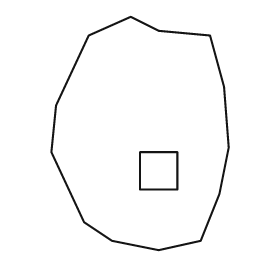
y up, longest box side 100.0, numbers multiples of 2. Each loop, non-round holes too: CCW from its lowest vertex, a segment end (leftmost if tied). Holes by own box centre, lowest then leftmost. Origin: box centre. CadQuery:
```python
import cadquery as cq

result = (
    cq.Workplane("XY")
    .moveTo(8.0, -50.0)
    .lineTo(26.0, -46.0)
    .lineTo(34.0, -26.0)
    .lineTo(38.0, -6.0)
    .lineTo(36.0, 20.0)
    .lineTo(30.0, 42.0)
    .lineTo(8.0, 44.0)
    .lineTo(-4.0, 50.0)
    .lineTo(-22.0, 42.0)
    .lineTo(-36.0, 12.0)
    .lineTo(-38.0, -8.0)
    .lineTo(-24.0, -38.0)
    .lineTo(-12.0, -46.0)
    .close()
    .moveTo(0.0, -24.0)
    .lineTo(16.0, -24.0)
    .lineTo(16.0, -8.0)
    .lineTo(0.0, -8.0)
    .close()
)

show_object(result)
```